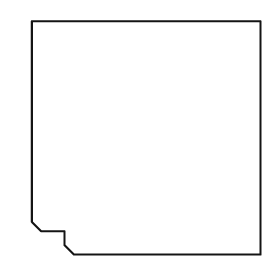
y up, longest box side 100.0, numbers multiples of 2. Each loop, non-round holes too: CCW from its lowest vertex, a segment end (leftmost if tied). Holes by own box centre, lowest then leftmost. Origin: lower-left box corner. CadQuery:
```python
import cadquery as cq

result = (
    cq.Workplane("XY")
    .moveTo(18.0, 0.0)
    .lineTo(98.0, 0.0)
    .lineTo(98.0, 100.0)
    .lineTo(0.0, 100.0)
    .lineTo(0.0, 14.0)
    .lineTo(4.0, 10.0)
    .lineTo(14.0, 10.0)
    .lineTo(14.0, 4.0)
    .close()
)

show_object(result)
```